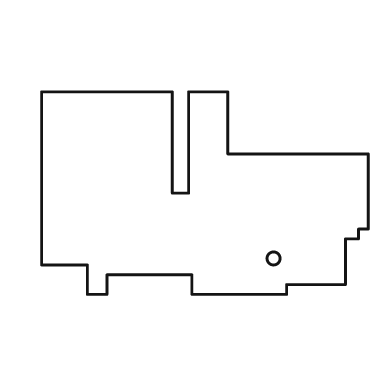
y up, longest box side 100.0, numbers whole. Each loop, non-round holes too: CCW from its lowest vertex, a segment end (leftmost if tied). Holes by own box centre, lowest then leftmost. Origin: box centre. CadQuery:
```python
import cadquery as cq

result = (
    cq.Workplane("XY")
    .moveTo(-36.0, -31.0)
    .lineTo(-30.0, -31.0)
    .lineTo(-30.0, -25.0)
    .lineTo(-4.0, -25.0)
    .lineTo(-4.0, -31.0)
    .lineTo(25.0, -31.0)
    .lineTo(25.0, -28.0)
    .lineTo(43.0, -28.0)
    .lineTo(43.0, -14.0)
    .lineTo(47.0, -14.0)
    .lineTo(47.0, -11.0)
    .lineTo(50.0, -11.0)
    .lineTo(50.0, 12.0)
    .lineTo(7.0, 12.0)
    .lineTo(7.0, 31.0)
    .lineTo(-5.0, 31.0)
    .lineTo(-5.0, 0.0)
    .lineTo(-10.0, 0.0)
    .lineTo(-10.0, 31.0)
    .lineTo(-50.0, 31.0)
    .lineTo(-50.0, -22.0)
    .lineTo(-36.0, -22.0)
    .close()
    .moveTo(21.0, -20.0)
    .circle(2.0)
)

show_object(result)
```